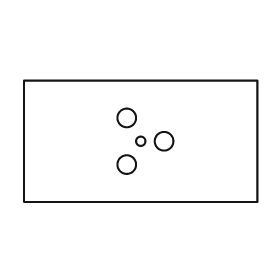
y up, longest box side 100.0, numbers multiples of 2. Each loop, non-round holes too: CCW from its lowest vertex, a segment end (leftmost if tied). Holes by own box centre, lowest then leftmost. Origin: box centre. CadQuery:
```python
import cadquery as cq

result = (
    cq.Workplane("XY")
    .moveTo(-50.0, -26.0)
    .lineTo(50.0, -26.0)
    .lineTo(50.0, 26.0)
    .lineTo(-50.0, 26.0)
    .close()
    .moveTo(-6.0, -10.0)
    .circle(4.0)
    .moveTo(0.0, 0.0)
    .circle(2.0)
    .moveTo(10.0, 0.0)
    .circle(4.0)
    .moveTo(-6.0, 10.0)
    .circle(4.0)
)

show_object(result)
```